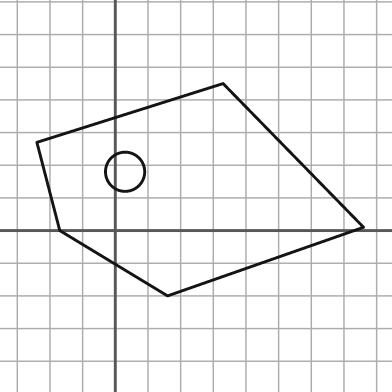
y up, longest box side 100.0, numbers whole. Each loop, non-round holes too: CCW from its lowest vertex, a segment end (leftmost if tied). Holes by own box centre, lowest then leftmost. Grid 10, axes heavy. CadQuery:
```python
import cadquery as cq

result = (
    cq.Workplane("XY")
    .moveTo(16.0, -20.0)
    .lineTo(76.0, 1.0)
    .lineTo(33.0, 45.0)
    .lineTo(-24.0, 27.0)
    .lineTo(-17.0, 0.0)
    .close()
    .moveTo(3.0, 18.0)
    .circle(6.0)
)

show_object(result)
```